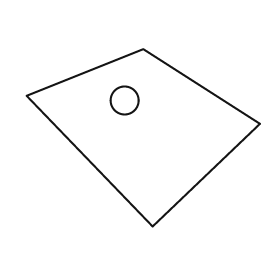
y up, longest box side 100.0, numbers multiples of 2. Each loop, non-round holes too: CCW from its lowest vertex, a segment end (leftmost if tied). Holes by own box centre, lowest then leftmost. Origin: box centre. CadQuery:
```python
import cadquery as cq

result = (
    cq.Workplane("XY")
    .moveTo(4.0, -38.0)
    .lineTo(50.0, 6.0)
    .lineTo(0.0, 38.0)
    .lineTo(-50.0, 18.0)
    .close()
    .moveTo(-8.0, 16.0)
    .circle(6.0)
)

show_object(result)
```